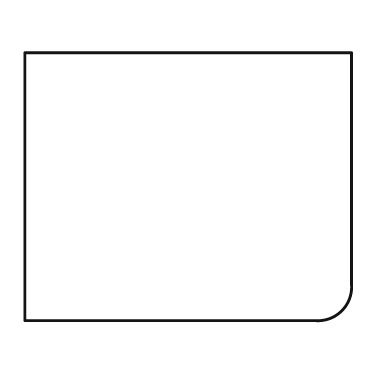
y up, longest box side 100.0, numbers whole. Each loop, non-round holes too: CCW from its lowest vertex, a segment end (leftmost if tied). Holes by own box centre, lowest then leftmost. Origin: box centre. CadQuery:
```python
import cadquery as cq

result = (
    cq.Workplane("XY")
    .moveTo(-50.0, -41.0)
    .lineTo(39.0, -41.0)
    .threePointArc((47.0, -38.0), (50.0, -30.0))
    .lineTo(50.0, 41.0)
    .lineTo(-50.0, 41.0)
    .close()
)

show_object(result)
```